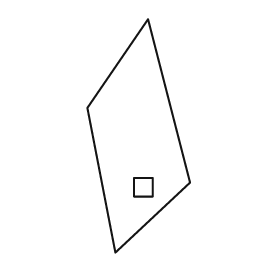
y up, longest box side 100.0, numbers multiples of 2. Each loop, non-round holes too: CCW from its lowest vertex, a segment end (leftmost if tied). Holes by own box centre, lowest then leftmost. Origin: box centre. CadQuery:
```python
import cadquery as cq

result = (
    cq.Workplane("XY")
    .moveTo(-10.0, -50.0)
    .lineTo(22.0, -20.0)
    .lineTo(4.0, 50.0)
    .lineTo(-22.0, 12.0)
    .close()
    .moveTo(-2.0, -26.0)
    .lineTo(6.0, -26.0)
    .lineTo(6.0, -18.0)
    .lineTo(-2.0, -18.0)
    .close()
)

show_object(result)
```